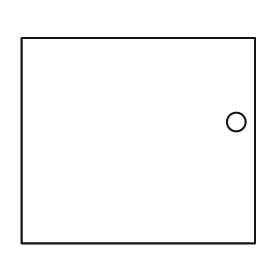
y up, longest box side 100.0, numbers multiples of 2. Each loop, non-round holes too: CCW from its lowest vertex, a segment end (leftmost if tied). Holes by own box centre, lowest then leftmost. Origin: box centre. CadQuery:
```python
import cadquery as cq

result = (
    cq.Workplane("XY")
    .moveTo(-50.0, -44.0)
    .lineTo(50.0, -44.0)
    .lineTo(50.0, 44.0)
    .lineTo(-50.0, 44.0)
    .close()
    .moveTo(42.0, 8.0)
    .circle(4.0)
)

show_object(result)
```